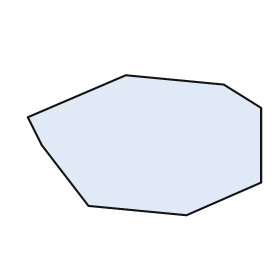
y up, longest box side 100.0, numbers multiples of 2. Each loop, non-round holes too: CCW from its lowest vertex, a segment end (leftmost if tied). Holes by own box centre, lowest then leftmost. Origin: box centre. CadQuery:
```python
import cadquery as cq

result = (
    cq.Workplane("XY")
    .moveTo(18.0, -30.0)
    .lineTo(50.0, -16.0)
    .lineTo(50.0, 16.0)
    .lineTo(34.0, 26.0)
    .lineTo(-8.0, 30.0)
    .lineTo(-50.0, 12.0)
    .lineTo(-44.0, 0.0)
    .lineTo(-24.0, -26.0)
    .close()
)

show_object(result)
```